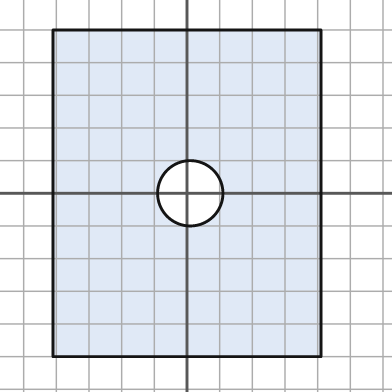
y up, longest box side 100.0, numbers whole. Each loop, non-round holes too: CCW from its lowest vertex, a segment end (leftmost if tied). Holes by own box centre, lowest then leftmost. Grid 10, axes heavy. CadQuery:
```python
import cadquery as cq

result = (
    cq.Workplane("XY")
    .moveTo(-41.0, -50.0)
    .lineTo(41.0, -50.0)
    .lineTo(41.0, 50.0)
    .lineTo(-41.0, 50.0)
    .close()
    .moveTo(1.0, 0.0)
    .circle(10.0)
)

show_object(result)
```